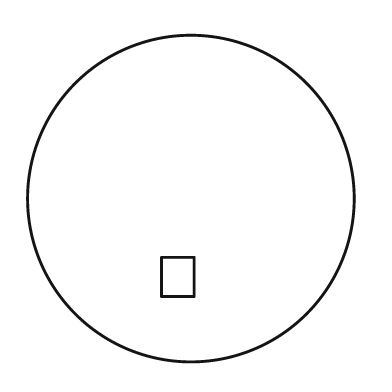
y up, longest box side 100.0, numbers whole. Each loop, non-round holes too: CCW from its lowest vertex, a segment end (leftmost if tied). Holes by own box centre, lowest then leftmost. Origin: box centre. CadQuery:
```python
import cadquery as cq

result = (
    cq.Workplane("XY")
    .moveTo(0.0, 0.0)
    .circle(50.0)
    .moveTo(-9.0, -30.0)
    .lineTo(1.0, -30.0)
    .lineTo(1.0, -18.0)
    .lineTo(-9.0, -18.0)
    .close()
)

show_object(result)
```